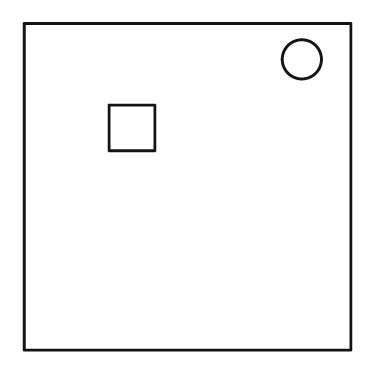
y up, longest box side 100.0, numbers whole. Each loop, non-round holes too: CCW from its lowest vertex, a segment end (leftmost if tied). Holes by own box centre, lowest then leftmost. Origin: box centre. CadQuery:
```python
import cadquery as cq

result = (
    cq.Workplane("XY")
    .moveTo(-50.0, -50.0)
    .lineTo(50.0, -50.0)
    .lineTo(50.0, 50.0)
    .lineTo(-50.0, 50.0)
    .close()
    .moveTo(-24.0, 11.0)
    .lineTo(-10.0, 11.0)
    .lineTo(-10.0, 25.0)
    .lineTo(-24.0, 25.0)
    .close()
    .moveTo(35.0, 39.0)
    .circle(6.0)
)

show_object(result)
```